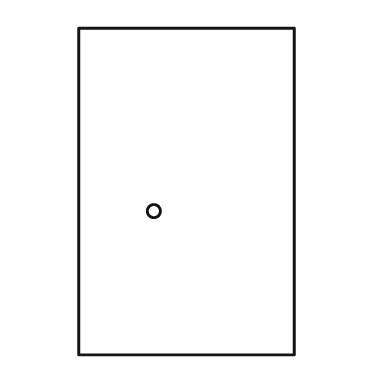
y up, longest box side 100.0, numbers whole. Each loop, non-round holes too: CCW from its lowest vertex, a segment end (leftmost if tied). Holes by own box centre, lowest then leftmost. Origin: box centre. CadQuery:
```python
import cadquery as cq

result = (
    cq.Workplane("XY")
    .moveTo(-33.0, -50.0)
    .lineTo(33.0, -50.0)
    .lineTo(33.0, 50.0)
    .lineTo(-33.0, 50.0)
    .close()
    .moveTo(-10.0, -6.0)
    .circle(2.0)
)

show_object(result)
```